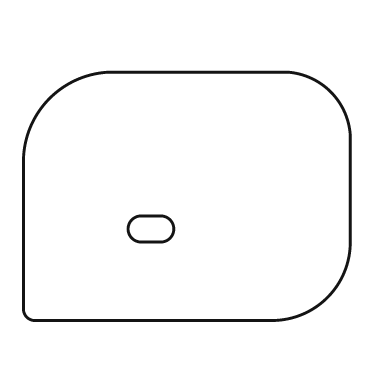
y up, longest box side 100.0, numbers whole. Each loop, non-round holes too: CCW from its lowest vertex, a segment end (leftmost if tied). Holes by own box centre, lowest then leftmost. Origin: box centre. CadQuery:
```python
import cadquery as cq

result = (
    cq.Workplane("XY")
    .moveTo(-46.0, -38.0)
    .lineTo(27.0, -38.0)
    .threePointArc((43.0, -31.0), (50.0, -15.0))
    .lineTo(50.0, 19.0)
    .threePointArc((44.0, 32.0), (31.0, 38.0))
    .lineTo(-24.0, 38.0)
    .threePointArc((-42.0, 30.0), (-50.0, 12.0))
    .lineTo(-50.0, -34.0)
    .threePointArc((-49.0, -37.0), (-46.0, -38.0))
    .close()
    .moveTo(-14.0, -14.0)
    .lineTo(-8.0, -14.0)
    .threePointArc((-4.0, -10.0), (-8.0, -6.0))
    .lineTo(-14.0, -6.0)
    .threePointArc((-18.0, -10.0), (-14.0, -14.0))
    .close()
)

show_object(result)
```